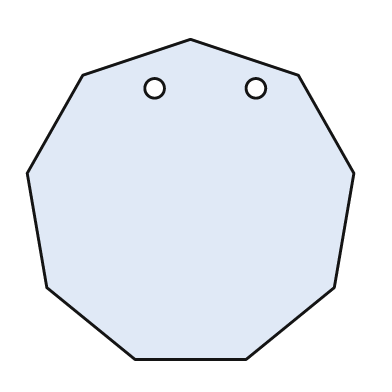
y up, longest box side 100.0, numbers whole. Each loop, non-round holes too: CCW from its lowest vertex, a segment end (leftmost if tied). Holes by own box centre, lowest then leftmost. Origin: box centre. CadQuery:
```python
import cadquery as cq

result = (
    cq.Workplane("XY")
    .moveTo(-17.0, -49.0)
    .lineTo(17.0, -49.0)
    .lineTo(44.0, -27.0)
    .lineTo(50.0, 8.0)
    .lineTo(33.0, 38.0)
    .lineTo(0.0, 49.0)
    .lineTo(-33.0, 38.0)
    .lineTo(-50.0, 8.0)
    .lineTo(-44.0, -27.0)
    .close()
    .moveTo(-11.0, 34.0)
    .circle(3.0)
    .moveTo(20.0, 34.0)
    .circle(3.0)
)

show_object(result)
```